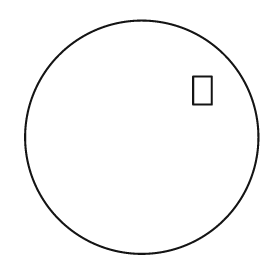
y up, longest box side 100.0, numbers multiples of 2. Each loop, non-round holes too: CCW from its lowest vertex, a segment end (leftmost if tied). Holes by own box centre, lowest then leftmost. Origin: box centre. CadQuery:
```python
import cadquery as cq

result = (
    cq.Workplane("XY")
    .moveTo(0.0, 0.0)
    .circle(50.0)
    .moveTo(22.0, 14.0)
    .lineTo(30.0, 14.0)
    .lineTo(30.0, 26.0)
    .lineTo(22.0, 26.0)
    .close()
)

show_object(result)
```